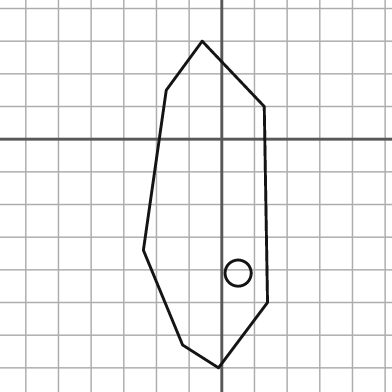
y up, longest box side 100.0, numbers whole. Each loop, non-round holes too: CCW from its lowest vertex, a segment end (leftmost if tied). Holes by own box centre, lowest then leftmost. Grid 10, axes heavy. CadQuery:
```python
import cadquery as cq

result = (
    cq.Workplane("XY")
    .moveTo(-1.0, -70.0)
    .lineTo(14.0, -50.0)
    .lineTo(13.0, 10.0)
    .lineTo(-6.0, 30.0)
    .lineTo(-17.0, 15.0)
    .lineTo(-24.0, -34.0)
    .lineTo(-12.0, -63.0)
    .close()
    .moveTo(5.0, -41.0)
    .circle(4.0)
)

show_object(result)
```